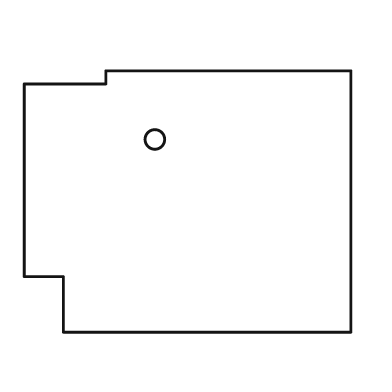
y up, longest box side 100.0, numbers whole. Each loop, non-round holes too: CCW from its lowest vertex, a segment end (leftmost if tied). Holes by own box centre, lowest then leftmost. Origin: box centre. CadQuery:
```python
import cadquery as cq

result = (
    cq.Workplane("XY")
    .moveTo(-38.0, -40.0)
    .lineTo(50.0, -40.0)
    .lineTo(50.0, 40.0)
    .lineTo(-25.0, 40.0)
    .lineTo(-25.0, 36.0)
    .lineTo(-50.0, 36.0)
    .lineTo(-50.0, -23.0)
    .lineTo(-38.0, -23.0)
    .close()
    .moveTo(-10.0, 19.0)
    .circle(3.0)
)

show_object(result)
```